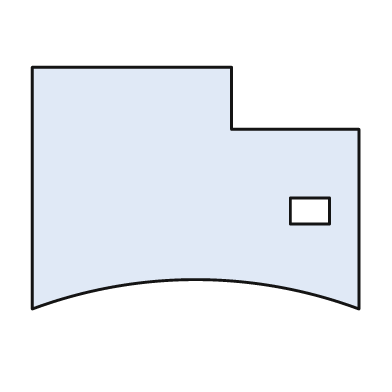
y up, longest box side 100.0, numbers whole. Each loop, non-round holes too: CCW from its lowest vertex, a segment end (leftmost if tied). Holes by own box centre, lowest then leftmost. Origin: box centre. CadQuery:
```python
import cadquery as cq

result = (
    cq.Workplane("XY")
    .moveTo(-50.0, -37.0)
    .threePointArc((0.0, -28.0), (50.0, -37.0))
    .lineTo(50.0, 18.0)
    .lineTo(11.0, 18.0)
    .lineTo(11.0, 37.0)
    .lineTo(-50.0, 37.0)
    .close()
    .moveTo(29.0, -11.0)
    .lineTo(41.0, -11.0)
    .lineTo(41.0, -3.0)
    .lineTo(29.0, -3.0)
    .close()
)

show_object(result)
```